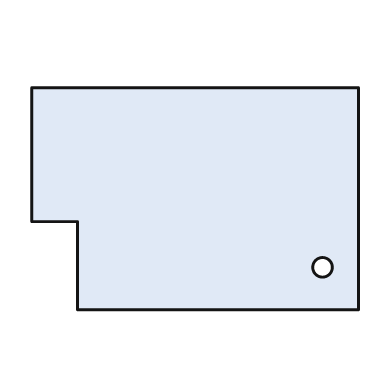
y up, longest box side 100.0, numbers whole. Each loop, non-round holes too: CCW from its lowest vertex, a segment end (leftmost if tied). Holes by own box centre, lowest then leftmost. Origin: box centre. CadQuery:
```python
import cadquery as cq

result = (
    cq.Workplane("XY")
    .moveTo(-36.0, -34.0)
    .lineTo(50.0, -34.0)
    .lineTo(50.0, 34.0)
    .lineTo(-50.0, 34.0)
    .lineTo(-50.0, -7.0)
    .lineTo(-36.0, -7.0)
    .close()
    .moveTo(39.0, -21.0)
    .circle(3.0)
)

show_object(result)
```